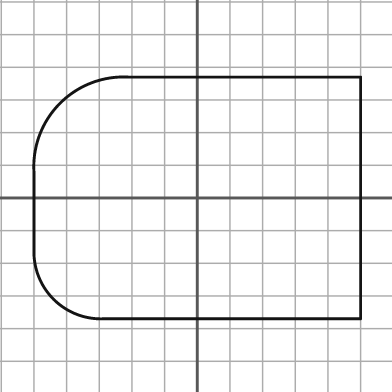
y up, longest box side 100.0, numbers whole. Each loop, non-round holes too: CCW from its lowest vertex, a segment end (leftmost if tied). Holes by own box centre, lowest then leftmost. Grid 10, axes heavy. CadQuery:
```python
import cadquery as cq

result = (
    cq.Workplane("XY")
    .moveTo(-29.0, -37.0)
    .lineTo(50.0, -37.0)
    .lineTo(50.0, 37.0)
    .lineTo(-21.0, 37.0)
    .threePointArc((-42.0, 29.0), (-50.0, 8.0))
    .lineTo(-50.0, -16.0)
    .threePointArc((-44.0, -31.0), (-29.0, -37.0))
    .close()
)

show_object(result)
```